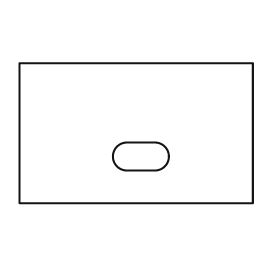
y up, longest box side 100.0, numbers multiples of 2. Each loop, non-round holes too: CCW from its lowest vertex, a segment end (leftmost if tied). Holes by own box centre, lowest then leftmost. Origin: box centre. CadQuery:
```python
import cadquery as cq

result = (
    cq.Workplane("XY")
    .moveTo(-50.0, -30.0)
    .lineTo(50.0, -30.0)
    .lineTo(50.0, 30.0)
    .lineTo(-50.0, 30.0)
    .close()
    .moveTo(-4.0, -16.0)
    .lineTo(8.0, -16.0)
    .threePointArc((14.0, -10.0), (8.0, -4.0))
    .lineTo(-4.0, -4.0)
    .threePointArc((-10.0, -10.0), (-4.0, -16.0))
    .close()
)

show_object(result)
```